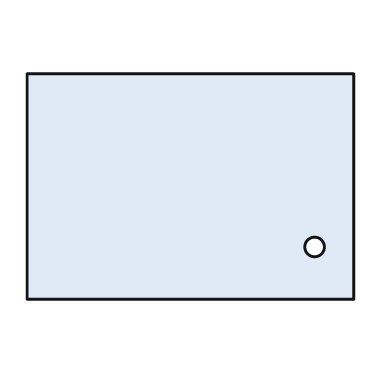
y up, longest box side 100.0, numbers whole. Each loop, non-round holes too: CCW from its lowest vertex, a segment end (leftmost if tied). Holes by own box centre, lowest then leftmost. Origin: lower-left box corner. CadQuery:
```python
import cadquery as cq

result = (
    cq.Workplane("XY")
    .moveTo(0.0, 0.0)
    .lineTo(100.0, 0.0)
    .lineTo(100.0, 69.0)
    .lineTo(0.0, 69.0)
    .close()
    .moveTo(88.0, 16.0)
    .circle(3.0)
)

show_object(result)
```